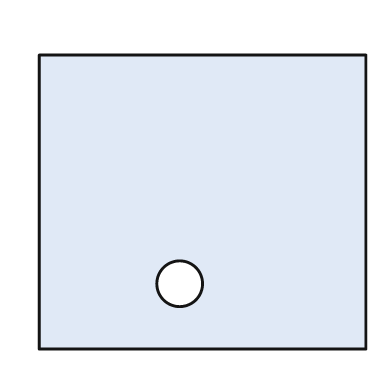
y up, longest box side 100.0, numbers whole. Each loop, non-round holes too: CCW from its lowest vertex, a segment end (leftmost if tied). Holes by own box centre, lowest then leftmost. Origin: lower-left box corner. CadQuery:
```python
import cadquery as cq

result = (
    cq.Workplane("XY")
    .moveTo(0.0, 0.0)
    .lineTo(100.0, 0.0)
    .lineTo(100.0, 90.0)
    .lineTo(0.0, 90.0)
    .close()
    .moveTo(43.0, 20.0)
    .circle(7.0)
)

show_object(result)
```